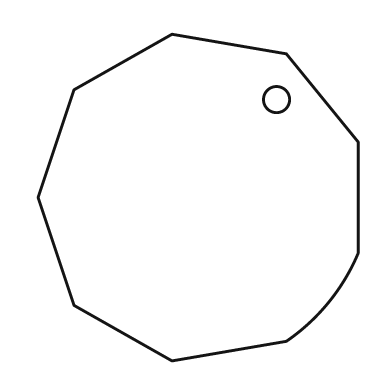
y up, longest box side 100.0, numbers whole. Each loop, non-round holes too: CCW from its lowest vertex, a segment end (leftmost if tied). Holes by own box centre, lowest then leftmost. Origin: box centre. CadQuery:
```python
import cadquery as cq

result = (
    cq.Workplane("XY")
    .moveTo(-8.0, -50.0)
    .lineTo(27.0, -44.0)
    .threePointArc((40.0, -32.0), (49.0, -17.0))
    .lineTo(49.0, 17.0)
    .lineTo(27.0, 44.0)
    .lineTo(-8.0, 50.0)
    .lineTo(-38.0, 33.0)
    .lineTo(-49.0, 0.0)
    .lineTo(-38.0, -33.0)
    .close()
    .moveTo(24.0, 30.0)
    .circle(4.0)
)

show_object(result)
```